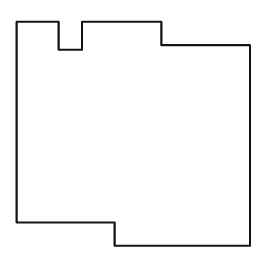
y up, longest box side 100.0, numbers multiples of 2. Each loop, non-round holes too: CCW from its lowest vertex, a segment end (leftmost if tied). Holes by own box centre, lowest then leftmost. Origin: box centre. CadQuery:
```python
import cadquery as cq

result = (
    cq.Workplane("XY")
    .moveTo(-8.0, -48.0)
    .lineTo(50.0, -48.0)
    .lineTo(50.0, 38.0)
    .lineTo(12.0, 38.0)
    .lineTo(12.0, 48.0)
    .lineTo(-22.0, 48.0)
    .lineTo(-22.0, 36.0)
    .lineTo(-32.0, 36.0)
    .lineTo(-32.0, 48.0)
    .lineTo(-50.0, 48.0)
    .lineTo(-50.0, -38.0)
    .lineTo(-8.0, -38.0)
    .close()
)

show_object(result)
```